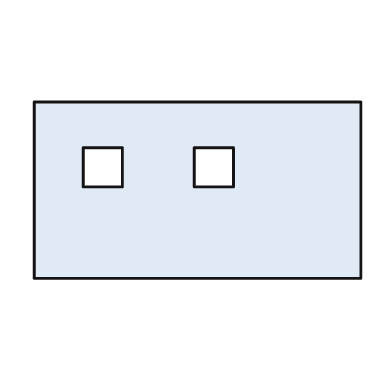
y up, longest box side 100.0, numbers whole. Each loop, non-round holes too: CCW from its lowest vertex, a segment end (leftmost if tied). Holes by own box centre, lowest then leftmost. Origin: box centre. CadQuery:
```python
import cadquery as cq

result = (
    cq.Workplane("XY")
    .moveTo(-50.0, -27.0)
    .lineTo(50.0, -27.0)
    .lineTo(50.0, 27.0)
    .lineTo(-50.0, 27.0)
    .close()
    .moveTo(-35.0, 1.0)
    .lineTo(-23.0, 1.0)
    .lineTo(-23.0, 13.0)
    .lineTo(-35.0, 13.0)
    .close()
    .moveTo(-1.0, 1.0)
    .lineTo(11.0, 1.0)
    .lineTo(11.0, 13.0)
    .lineTo(-1.0, 13.0)
    .close()
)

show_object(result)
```